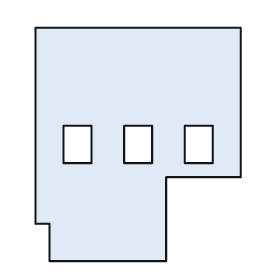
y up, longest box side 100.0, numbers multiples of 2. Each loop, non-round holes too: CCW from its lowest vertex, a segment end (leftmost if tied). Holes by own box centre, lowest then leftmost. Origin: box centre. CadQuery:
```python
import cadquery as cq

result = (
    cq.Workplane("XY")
    .moveTo(-38.0, -50.0)
    .lineTo(12.0, -50.0)
    .lineTo(12.0, -14.0)
    .lineTo(44.0, -14.0)
    .lineTo(44.0, 50.0)
    .lineTo(-44.0, 50.0)
    .lineTo(-44.0, -34.0)
    .lineTo(-38.0, -34.0)
    .close()
    .moveTo(-32.0, -8.0)
    .lineTo(-20.0, -8.0)
    .lineTo(-20.0, 8.0)
    .lineTo(-32.0, 8.0)
    .close()
    .moveTo(-6.0, -8.0)
    .lineTo(6.0, -8.0)
    .lineTo(6.0, 8.0)
    .lineTo(-6.0, 8.0)
    .close()
    .moveTo(20.0, -8.0)
    .lineTo(32.0, -8.0)
    .lineTo(32.0, 8.0)
    .lineTo(20.0, 8.0)
    .close()
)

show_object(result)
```